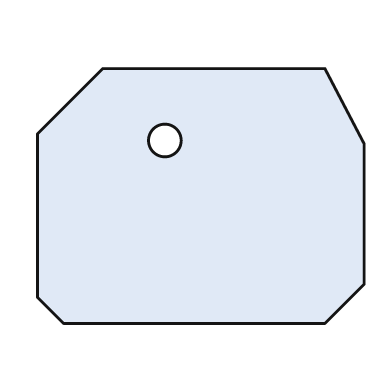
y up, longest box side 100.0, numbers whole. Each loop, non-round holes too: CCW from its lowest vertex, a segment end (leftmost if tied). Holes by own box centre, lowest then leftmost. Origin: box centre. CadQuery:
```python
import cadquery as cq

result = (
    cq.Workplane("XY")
    .moveTo(-42.0, -39.0)
    .lineTo(38.0, -39.0)
    .lineTo(50.0, -27.0)
    .lineTo(50.0, 16.0)
    .lineTo(38.0, 39.0)
    .lineTo(-30.0, 39.0)
    .lineTo(-50.0, 19.0)
    .lineTo(-50.0, -31.0)
    .close()
    .moveTo(-11.0, 17.0)
    .circle(5.0)
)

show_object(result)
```